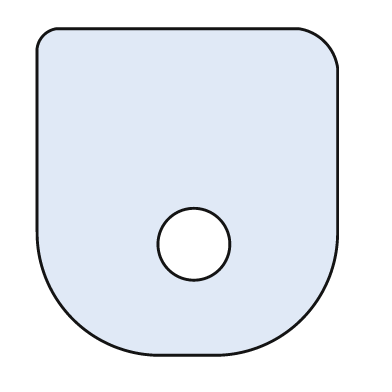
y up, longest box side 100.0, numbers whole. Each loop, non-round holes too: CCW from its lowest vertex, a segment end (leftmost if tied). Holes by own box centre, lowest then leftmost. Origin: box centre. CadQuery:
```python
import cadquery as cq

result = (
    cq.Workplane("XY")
    .moveTo(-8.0, -50.0)
    .lineTo(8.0, -50.0)
    .threePointArc((35.0, -39.0), (46.0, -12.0))
    .lineTo(46.0, 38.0)
    .threePointArc((42.0, 46.0), (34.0, 50.0))
    .lineTo(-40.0, 50.0)
    .threePointArc((-44.0, 48.0), (-46.0, 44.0))
    .lineTo(-46.0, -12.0)
    .threePointArc((-35.0, -39.0), (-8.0, -50.0))
    .close()
    .moveTo(2.0, -16.0)
    .circle(11.0)
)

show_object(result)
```